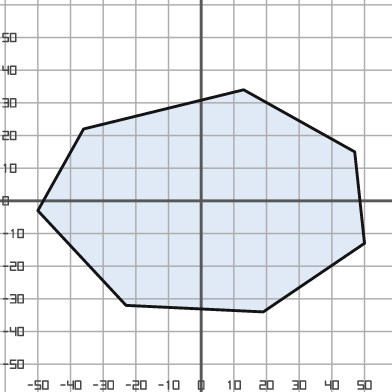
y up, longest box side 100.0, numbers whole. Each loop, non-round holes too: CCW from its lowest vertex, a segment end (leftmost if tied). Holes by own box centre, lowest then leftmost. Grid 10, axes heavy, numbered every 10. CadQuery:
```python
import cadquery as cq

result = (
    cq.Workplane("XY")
    .moveTo(19.0, -34.0)
    .lineTo(50.0, -13.0)
    .lineTo(47.0, 15.0)
    .lineTo(13.0, 34.0)
    .lineTo(-36.0, 22.0)
    .lineTo(-50.0, -3.0)
    .lineTo(-23.0, -32.0)
    .close()
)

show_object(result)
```